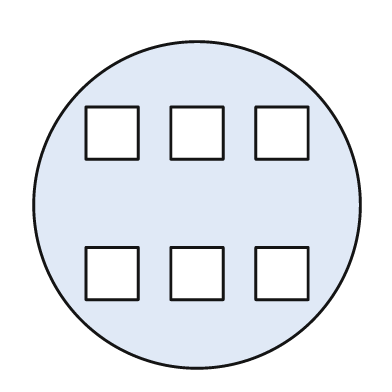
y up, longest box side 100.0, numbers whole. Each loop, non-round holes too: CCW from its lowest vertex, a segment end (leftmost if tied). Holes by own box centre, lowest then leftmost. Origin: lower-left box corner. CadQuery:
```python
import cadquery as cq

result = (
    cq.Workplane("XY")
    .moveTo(50.0, 50.0)
    .circle(50.0)
    .moveTo(16.0, 21.0)
    .lineTo(32.0, 21.0)
    .lineTo(32.0, 37.0)
    .lineTo(16.0, 37.0)
    .close()
    .moveTo(42.0, 21.0)
    .lineTo(58.0, 21.0)
    .lineTo(58.0, 37.0)
    .lineTo(42.0, 37.0)
    .close()
    .moveTo(68.0, 21.0)
    .lineTo(84.0, 21.0)
    .lineTo(84.0, 37.0)
    .lineTo(68.0, 37.0)
    .close()
    .moveTo(16.0, 64.0)
    .lineTo(32.0, 64.0)
    .lineTo(32.0, 80.0)
    .lineTo(16.0, 80.0)
    .close()
    .moveTo(42.0, 64.0)
    .lineTo(58.0, 64.0)
    .lineTo(58.0, 80.0)
    .lineTo(42.0, 80.0)
    .close()
    .moveTo(68.0, 64.0)
    .lineTo(84.0, 64.0)
    .lineTo(84.0, 80.0)
    .lineTo(68.0, 80.0)
    .close()
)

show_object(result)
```